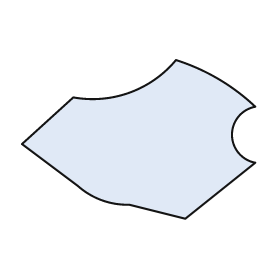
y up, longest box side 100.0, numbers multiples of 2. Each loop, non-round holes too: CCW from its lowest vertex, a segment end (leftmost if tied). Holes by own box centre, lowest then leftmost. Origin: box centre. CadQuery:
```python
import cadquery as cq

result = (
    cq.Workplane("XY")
    .moveTo(20.0, -34.0)
    .lineTo(50.0, -10.0)
    .threePointArc((40.0, 2.0), (50.0, 14.0))
    .threePointArc((34.0, 26.0), (16.0, 34.0))
    .threePointArc((-4.0, 20.0), (-28.0, 18.0))
    .lineTo(-50.0, -2.0)
    .lineTo(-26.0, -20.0)
    .threePointArc((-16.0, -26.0), (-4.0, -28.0))
    .close()
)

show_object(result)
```